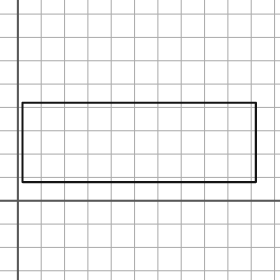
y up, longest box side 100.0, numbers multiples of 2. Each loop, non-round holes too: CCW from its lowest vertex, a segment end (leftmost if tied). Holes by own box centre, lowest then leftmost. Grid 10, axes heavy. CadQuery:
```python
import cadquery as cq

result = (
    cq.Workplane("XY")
    .moveTo(2.0, 8.0)
    .lineTo(102.0, 8.0)
    .lineTo(102.0, 42.0)
    .lineTo(2.0, 42.0)
    .close()
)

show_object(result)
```